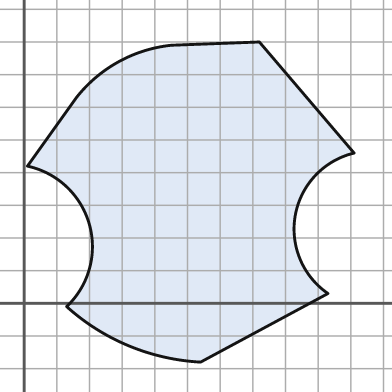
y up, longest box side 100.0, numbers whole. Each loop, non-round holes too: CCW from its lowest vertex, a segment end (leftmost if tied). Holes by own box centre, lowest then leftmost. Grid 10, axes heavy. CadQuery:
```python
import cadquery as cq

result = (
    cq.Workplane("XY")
    .moveTo(54.0, -18.0)
    .lineTo(93.0, 3.0)
    .threePointArc((83.0, 27.0), (101.0, 46.0))
    .lineTo(72.0, 80.0)
    .lineTo(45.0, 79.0)
    .threePointArc((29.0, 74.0), (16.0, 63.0))
    .lineTo(1.0, 42.0)
    .threePointArc((20.0, 24.0), (13.0, -1.0))
    .threePointArc((32.0, -13.0), (54.0, -18.0))
    .close()
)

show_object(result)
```